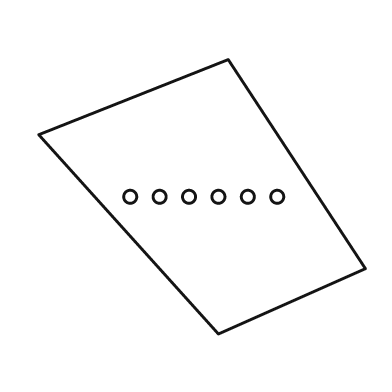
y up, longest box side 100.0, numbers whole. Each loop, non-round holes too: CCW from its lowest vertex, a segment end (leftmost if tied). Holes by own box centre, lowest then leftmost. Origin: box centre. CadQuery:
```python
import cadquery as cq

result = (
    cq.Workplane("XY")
    .moveTo(5.0, -42.0)
    .lineTo(50.0, -22.0)
    .lineTo(8.0, 42.0)
    .lineTo(-50.0, 19.0)
    .close()
    .moveTo(-22.0, 0.0)
    .circle(2.0)
    .moveTo(-13.0, 0.0)
    .circle(2.0)
    .moveTo(-4.0, 0.0)
    .circle(2.0)
    .moveTo(5.0, 0.0)
    .circle(2.0)
    .moveTo(14.0, 0.0)
    .circle(2.0)
    .moveTo(23.0, 0.0)
    .circle(2.0)
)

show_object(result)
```